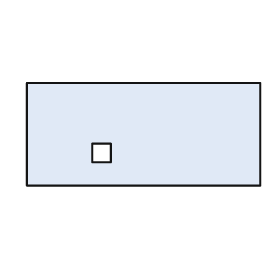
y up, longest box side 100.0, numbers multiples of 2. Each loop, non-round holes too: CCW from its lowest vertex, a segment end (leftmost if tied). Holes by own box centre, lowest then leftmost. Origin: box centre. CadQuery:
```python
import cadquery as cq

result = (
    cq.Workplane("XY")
    .moveTo(-50.0, -22.0)
    .lineTo(50.0, -22.0)
    .lineTo(50.0, 22.0)
    .lineTo(-50.0, 22.0)
    .close()
    .moveTo(-22.0, -12.0)
    .lineTo(-14.0, -12.0)
    .lineTo(-14.0, -4.0)
    .lineTo(-22.0, -4.0)
    .close()
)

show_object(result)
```